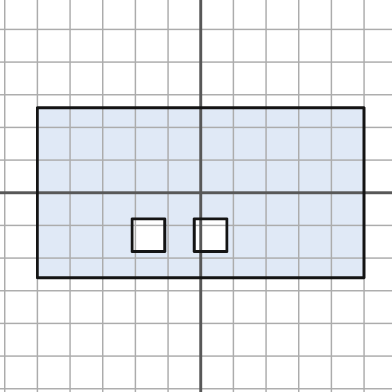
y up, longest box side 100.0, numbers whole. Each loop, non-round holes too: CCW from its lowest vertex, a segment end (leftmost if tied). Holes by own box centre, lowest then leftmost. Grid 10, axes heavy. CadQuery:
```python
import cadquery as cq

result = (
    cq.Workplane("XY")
    .moveTo(-50.0, -26.0)
    .lineTo(50.0, -26.0)
    .lineTo(50.0, 26.0)
    .lineTo(-50.0, 26.0)
    .close()
    .moveTo(-21.0, -18.0)
    .lineTo(-11.0, -18.0)
    .lineTo(-11.0, -8.0)
    .lineTo(-21.0, -8.0)
    .close()
    .moveTo(-2.0, -18.0)
    .lineTo(8.0, -18.0)
    .lineTo(8.0, -8.0)
    .lineTo(-2.0, -8.0)
    .close()
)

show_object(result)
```